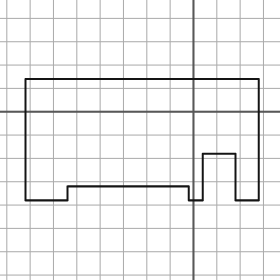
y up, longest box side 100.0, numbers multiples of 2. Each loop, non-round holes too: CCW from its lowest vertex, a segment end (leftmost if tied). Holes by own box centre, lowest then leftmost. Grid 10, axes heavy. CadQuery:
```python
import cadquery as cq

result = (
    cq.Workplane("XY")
    .moveTo(-72.0, -38.0)
    .lineTo(-54.0, -38.0)
    .lineTo(-54.0, -32.0)
    .lineTo(-2.0, -32.0)
    .lineTo(-2.0, -38.0)
    .lineTo(4.0, -38.0)
    .lineTo(4.0, -18.0)
    .lineTo(18.0, -18.0)
    .lineTo(18.0, -38.0)
    .lineTo(28.0, -38.0)
    .lineTo(28.0, 14.0)
    .lineTo(-72.0, 14.0)
    .close()
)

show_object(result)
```